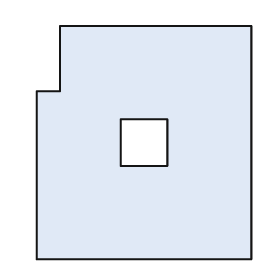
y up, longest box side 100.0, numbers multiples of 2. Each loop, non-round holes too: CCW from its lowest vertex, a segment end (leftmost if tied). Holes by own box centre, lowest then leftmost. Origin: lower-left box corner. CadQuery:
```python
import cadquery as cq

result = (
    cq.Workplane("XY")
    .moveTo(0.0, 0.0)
    .lineTo(92.0, 0.0)
    .lineTo(92.0, 100.0)
    .lineTo(10.0, 100.0)
    .lineTo(10.0, 72.0)
    .lineTo(0.0, 72.0)
    .close()
    .moveTo(36.0, 40.0)
    .lineTo(56.0, 40.0)
    .lineTo(56.0, 60.0)
    .lineTo(36.0, 60.0)
    .close()
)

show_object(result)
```